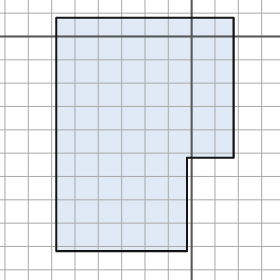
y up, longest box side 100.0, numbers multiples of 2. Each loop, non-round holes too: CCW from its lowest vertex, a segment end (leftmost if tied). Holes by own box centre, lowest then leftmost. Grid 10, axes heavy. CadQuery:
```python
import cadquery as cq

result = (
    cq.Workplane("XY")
    .moveTo(-58.0, -92.0)
    .lineTo(-2.0, -92.0)
    .lineTo(-2.0, -52.0)
    .lineTo(18.0, -52.0)
    .lineTo(18.0, 8.0)
    .lineTo(-58.0, 8.0)
    .close()
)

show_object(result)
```